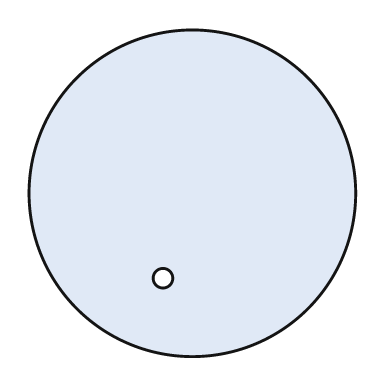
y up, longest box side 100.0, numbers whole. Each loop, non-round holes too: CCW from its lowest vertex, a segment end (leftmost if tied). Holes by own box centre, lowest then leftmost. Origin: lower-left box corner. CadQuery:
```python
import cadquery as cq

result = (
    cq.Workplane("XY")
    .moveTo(50.0, 50.0)
    .circle(50.0)
    .moveTo(41.0, 24.0)
    .circle(3.0)
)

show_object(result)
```